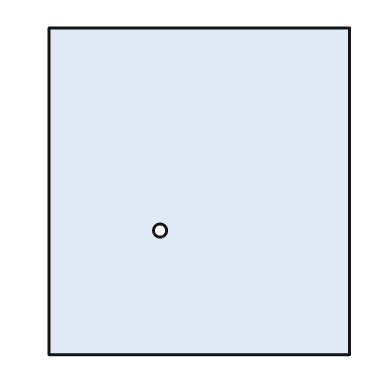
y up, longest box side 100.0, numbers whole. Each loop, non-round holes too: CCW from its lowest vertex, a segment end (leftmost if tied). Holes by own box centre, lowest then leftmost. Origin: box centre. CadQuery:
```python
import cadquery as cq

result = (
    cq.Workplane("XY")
    .moveTo(-46.0, -50.0)
    .lineTo(46.0, -50.0)
    .lineTo(46.0, 50.0)
    .lineTo(-46.0, 50.0)
    .close()
    .moveTo(-12.0, -12.0)
    .circle(2.0)
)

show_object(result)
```